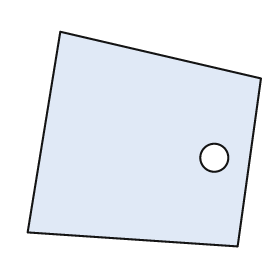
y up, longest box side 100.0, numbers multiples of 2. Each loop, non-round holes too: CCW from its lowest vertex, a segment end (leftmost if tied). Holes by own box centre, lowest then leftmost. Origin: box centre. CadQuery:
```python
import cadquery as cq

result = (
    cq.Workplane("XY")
    .moveTo(40.0, -46.0)
    .lineTo(50.0, 26.0)
    .lineTo(-36.0, 46.0)
    .lineTo(-50.0, -40.0)
    .close()
    .moveTo(30.0, -8.0)
    .circle(6.0)
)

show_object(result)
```